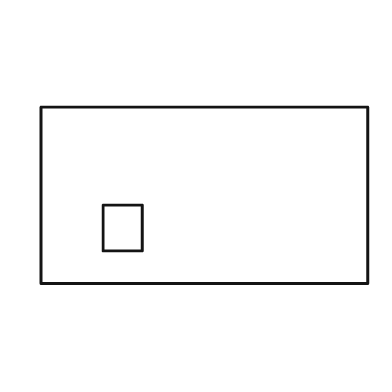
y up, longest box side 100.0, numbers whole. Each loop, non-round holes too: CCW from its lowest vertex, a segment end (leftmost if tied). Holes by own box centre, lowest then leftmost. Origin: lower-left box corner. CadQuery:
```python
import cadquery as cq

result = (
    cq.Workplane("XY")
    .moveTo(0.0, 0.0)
    .lineTo(100.0, 0.0)
    .lineTo(100.0, 54.0)
    .lineTo(0.0, 54.0)
    .close()
    .moveTo(19.0, 10.0)
    .lineTo(31.0, 10.0)
    .lineTo(31.0, 24.0)
    .lineTo(19.0, 24.0)
    .close()
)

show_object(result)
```